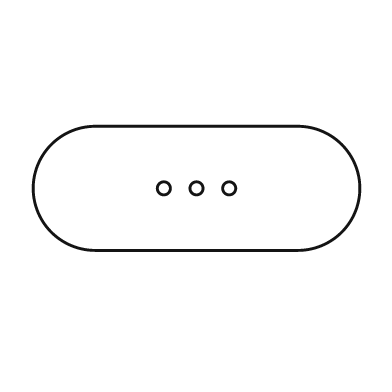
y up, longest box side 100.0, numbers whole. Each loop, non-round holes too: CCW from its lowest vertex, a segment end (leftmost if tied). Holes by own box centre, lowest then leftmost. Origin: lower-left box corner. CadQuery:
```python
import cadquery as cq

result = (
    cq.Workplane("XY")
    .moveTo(19.0, 0.0)
    .lineTo(81.0, 0.0)
    .threePointArc((100.0, 19.0), (81.0, 38.0))
    .lineTo(19.0, 38.0)
    .threePointArc((0.0, 19.0), (19.0, 0.0))
    .close()
    .moveTo(40.0, 19.0)
    .circle(2.0)
    .moveTo(50.0, 19.0)
    .circle(2.0)
    .moveTo(60.0, 19.0)
    .circle(2.0)
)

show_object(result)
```